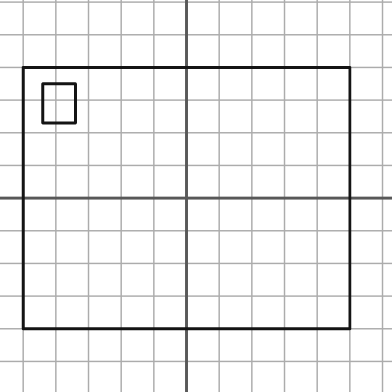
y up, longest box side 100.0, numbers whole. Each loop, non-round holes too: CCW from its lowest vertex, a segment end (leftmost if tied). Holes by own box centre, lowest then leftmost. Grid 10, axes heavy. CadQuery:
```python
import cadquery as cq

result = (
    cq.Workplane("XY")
    .moveTo(-50.0, -40.0)
    .lineTo(50.0, -40.0)
    .lineTo(50.0, 40.0)
    .lineTo(-50.0, 40.0)
    .close()
    .moveTo(-44.0, 23.0)
    .lineTo(-34.0, 23.0)
    .lineTo(-34.0, 35.0)
    .lineTo(-44.0, 35.0)
    .close()
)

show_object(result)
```